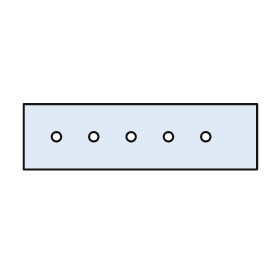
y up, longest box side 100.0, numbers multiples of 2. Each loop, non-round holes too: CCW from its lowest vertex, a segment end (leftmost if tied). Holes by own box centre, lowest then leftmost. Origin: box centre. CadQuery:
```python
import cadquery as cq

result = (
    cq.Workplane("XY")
    .moveTo(-50.0, -14.0)
    .lineTo(50.0, -14.0)
    .lineTo(50.0, 14.0)
    .lineTo(-50.0, 14.0)
    .close()
    .moveTo(-36.0, 0.0)
    .circle(2.0)
    .moveTo(-20.0, 0.0)
    .circle(2.0)
    .moveTo(-4.0, 0.0)
    .circle(2.0)
    .moveTo(12.0, 0.0)
    .circle(2.0)
    .moveTo(28.0, 0.0)
    .circle(2.0)
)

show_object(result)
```